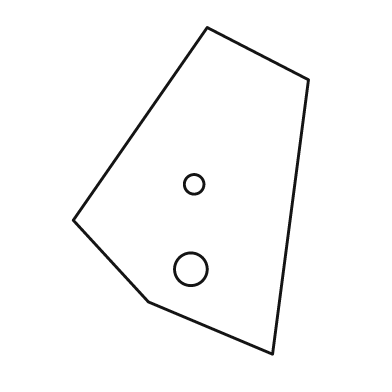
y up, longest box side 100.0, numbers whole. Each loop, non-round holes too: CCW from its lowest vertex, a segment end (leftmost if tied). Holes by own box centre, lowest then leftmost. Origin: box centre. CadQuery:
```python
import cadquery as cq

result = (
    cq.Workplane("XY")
    .moveTo(25.0, -50.0)
    .lineTo(36.0, 34.0)
    .lineTo(5.0, 50.0)
    .lineTo(-36.0, -9.0)
    .lineTo(-13.0, -34.0)
    .close()
    .moveTo(0.0, -24.0)
    .circle(5.0)
    .moveTo(1.0, 2.0)
    .circle(3.0)
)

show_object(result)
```